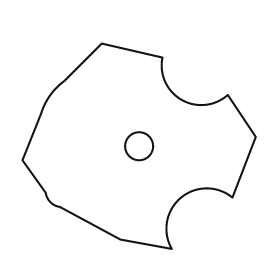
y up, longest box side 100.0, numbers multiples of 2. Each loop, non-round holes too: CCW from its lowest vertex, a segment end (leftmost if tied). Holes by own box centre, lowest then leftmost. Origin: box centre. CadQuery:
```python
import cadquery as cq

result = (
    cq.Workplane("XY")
    .moveTo(14.0, -44.0)
    .threePointArc((18.0, -22.0), (40.0, -22.0))
    .lineTo(50.0, 4.0)
    .lineTo(38.0, 22.0)
    .threePointArc((18.0, 20.0), (10.0, 38.0))
    .lineTo(-16.0, 44.0)
    .lineTo(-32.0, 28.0)
    .threePointArc((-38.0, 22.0), (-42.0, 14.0))
    .lineTo(-50.0, -6.0)
    .lineTo(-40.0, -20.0)
    .threePointArc((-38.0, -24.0), (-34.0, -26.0))
    .lineTo(-8.0, -40.0)
    .close()
    .moveTo(0.0, 0.0)
    .circle(6.0)
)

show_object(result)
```